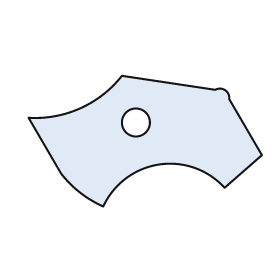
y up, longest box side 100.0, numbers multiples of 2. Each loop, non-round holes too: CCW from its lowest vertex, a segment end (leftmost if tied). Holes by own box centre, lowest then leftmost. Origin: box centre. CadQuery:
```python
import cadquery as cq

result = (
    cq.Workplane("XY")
    .moveTo(-18.0, -28.0)
    .threePointArc((6.0, -10.0), (34.0, -20.0))
    .lineTo(50.0, -6.0)
    .lineTo(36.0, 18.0)
    .threePointArc((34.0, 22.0), (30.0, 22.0))
    .lineTo(-10.0, 28.0)
    .threePointArc((-28.0, 14.0), (-50.0, 10.0))
    .lineTo(-36.0, -14.0)
    .threePointArc((-28.0, -22.0), (-18.0, -28.0))
    .close()
    .moveTo(-4.0, 8.0)
    .circle(6.0)
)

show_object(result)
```